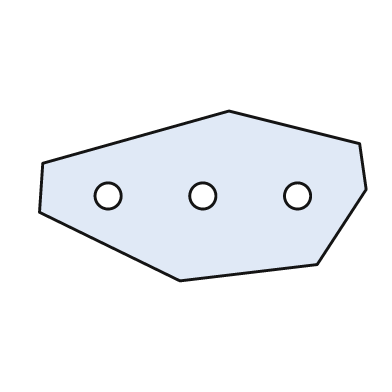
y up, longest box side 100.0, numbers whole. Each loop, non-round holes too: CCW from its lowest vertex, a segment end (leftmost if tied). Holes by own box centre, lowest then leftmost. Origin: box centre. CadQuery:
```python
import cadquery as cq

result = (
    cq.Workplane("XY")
    .moveTo(-7.0, -26.0)
    .lineTo(35.0, -21.0)
    .lineTo(50.0, 2.0)
    .lineTo(48.0, 16.0)
    .lineTo(8.0, 26.0)
    .lineTo(-49.0, 10.0)
    .lineTo(-50.0, -5.0)
    .close()
    .moveTo(-29.0, 0.0)
    .circle(4.0)
    .moveTo(0.0, 0.0)
    .circle(4.0)
    .moveTo(29.0, 0.0)
    .circle(4.0)
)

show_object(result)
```